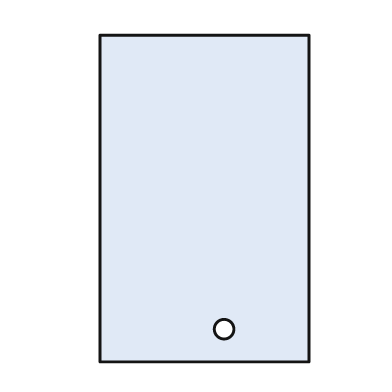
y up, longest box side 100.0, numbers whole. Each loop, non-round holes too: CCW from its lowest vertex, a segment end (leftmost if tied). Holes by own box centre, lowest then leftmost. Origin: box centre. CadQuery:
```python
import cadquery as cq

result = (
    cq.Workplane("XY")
    .moveTo(-32.0, -50.0)
    .lineTo(32.0, -50.0)
    .lineTo(32.0, 50.0)
    .lineTo(-32.0, 50.0)
    .close()
    .moveTo(6.0, -40.0)
    .circle(3.0)
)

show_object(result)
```